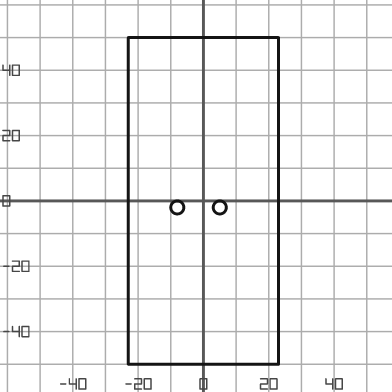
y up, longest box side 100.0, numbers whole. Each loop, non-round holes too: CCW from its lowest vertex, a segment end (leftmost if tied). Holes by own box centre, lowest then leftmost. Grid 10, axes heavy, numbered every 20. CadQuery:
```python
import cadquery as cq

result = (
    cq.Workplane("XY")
    .moveTo(-23.0, -50.0)
    .lineTo(23.0, -50.0)
    .lineTo(23.0, 50.0)
    .lineTo(-23.0, 50.0)
    .close()
    .moveTo(-8.0, -2.0)
    .circle(2.0)
    .moveTo(5.0, -2.0)
    .circle(2.0)
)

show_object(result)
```